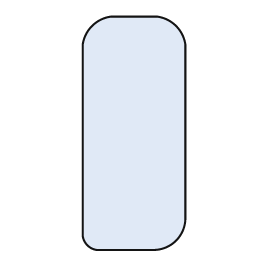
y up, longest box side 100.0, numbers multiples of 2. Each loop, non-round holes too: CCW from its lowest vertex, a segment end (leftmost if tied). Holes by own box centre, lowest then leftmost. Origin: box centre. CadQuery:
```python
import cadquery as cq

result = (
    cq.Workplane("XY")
    .moveTo(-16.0, -50.0)
    .lineTo(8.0, -50.0)
    .threePointArc((18.0, -46.0), (22.0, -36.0))
    .lineTo(22.0, 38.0)
    .threePointArc((18.0, 46.0), (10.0, 50.0))
    .lineTo(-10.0, 50.0)
    .threePointArc((-18.0, 46.0), (-22.0, 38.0))
    .lineTo(-22.0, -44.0)
    .threePointArc((-20.0, -48.0), (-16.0, -50.0))
    .close()
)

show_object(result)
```